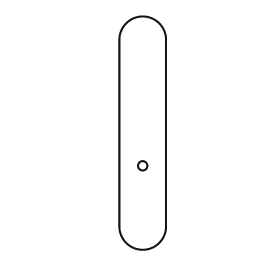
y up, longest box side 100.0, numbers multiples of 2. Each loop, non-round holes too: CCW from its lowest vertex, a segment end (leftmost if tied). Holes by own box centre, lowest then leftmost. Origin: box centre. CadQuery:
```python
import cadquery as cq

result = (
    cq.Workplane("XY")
    .moveTo(-10.0, -40.0)
    .threePointArc((0.0, -50.0), (10.0, -40.0))
    .lineTo(10.0, 40.0)
    .threePointArc((0.0, 50.0), (-10.0, 40.0))
    .close()
    .moveTo(0.0, -14.0)
    .circle(2.0)
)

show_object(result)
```